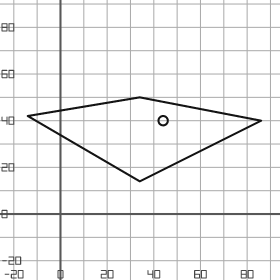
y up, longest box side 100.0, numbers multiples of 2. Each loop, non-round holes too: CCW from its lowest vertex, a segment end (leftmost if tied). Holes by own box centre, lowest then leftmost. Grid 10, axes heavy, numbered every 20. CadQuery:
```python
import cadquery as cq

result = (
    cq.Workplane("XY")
    .moveTo(34.0, 14.0)
    .lineTo(86.0, 40.0)
    .lineTo(34.0, 50.0)
    .lineTo(-14.0, 42.0)
    .close()
    .moveTo(44.0, 40.0)
    .circle(2.0)
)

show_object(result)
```